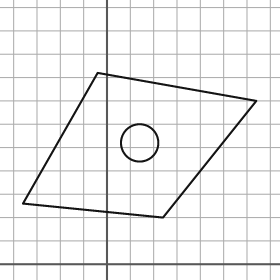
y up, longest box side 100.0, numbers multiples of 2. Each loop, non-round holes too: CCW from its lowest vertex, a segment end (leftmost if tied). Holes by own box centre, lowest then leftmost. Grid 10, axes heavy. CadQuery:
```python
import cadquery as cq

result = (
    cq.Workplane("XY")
    .moveTo(24.0, 20.0)
    .lineTo(64.0, 70.0)
    .lineTo(-4.0, 82.0)
    .lineTo(-36.0, 26.0)
    .close()
    .moveTo(14.0, 52.0)
    .circle(8.0)
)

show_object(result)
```